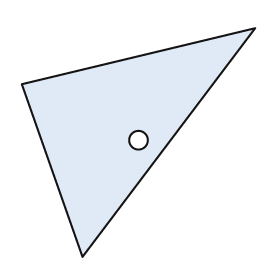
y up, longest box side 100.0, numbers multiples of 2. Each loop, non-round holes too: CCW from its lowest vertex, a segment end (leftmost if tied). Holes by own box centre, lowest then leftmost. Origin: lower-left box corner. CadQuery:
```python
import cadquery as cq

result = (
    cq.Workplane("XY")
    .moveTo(26.0, 0.0)
    .lineTo(100.0, 98.0)
    .lineTo(0.0, 74.0)
    .close()
    .moveTo(50.0, 50.0)
    .circle(4.0)
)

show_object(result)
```